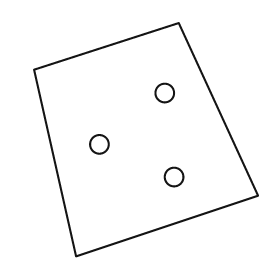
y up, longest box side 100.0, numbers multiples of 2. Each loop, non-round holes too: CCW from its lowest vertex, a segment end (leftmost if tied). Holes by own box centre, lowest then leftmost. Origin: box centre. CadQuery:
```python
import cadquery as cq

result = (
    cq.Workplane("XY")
    .moveTo(-30.0, -50.0)
    .lineTo(48.0, -24.0)
    .lineTo(14.0, 50.0)
    .lineTo(-48.0, 30.0)
    .close()
    .moveTo(12.0, -16.0)
    .circle(4.0)
    .moveTo(-20.0, -2.0)
    .circle(4.0)
    .moveTo(8.0, 20.0)
    .circle(4.0)
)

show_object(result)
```